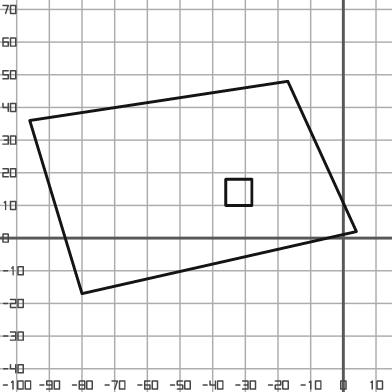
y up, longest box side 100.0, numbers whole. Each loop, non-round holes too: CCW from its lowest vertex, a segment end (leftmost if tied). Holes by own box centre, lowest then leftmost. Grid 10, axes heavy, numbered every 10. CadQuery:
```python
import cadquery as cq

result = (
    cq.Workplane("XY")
    .moveTo(-80.0, -17.0)
    .lineTo(4.0, 2.0)
    .lineTo(-17.0, 48.0)
    .lineTo(-96.0, 36.0)
    .close()
    .moveTo(-36.0, 10.0)
    .lineTo(-28.0, 10.0)
    .lineTo(-28.0, 18.0)
    .lineTo(-36.0, 18.0)
    .close()
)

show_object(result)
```